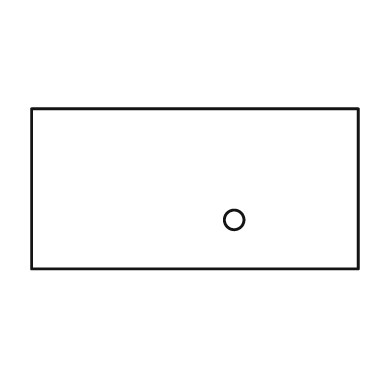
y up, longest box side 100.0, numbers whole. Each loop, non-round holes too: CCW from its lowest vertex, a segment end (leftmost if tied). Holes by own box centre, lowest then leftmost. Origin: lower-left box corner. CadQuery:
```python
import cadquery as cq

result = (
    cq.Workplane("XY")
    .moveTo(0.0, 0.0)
    .lineTo(100.0, 0.0)
    .lineTo(100.0, 49.0)
    .lineTo(0.0, 49.0)
    .close()
    .moveTo(62.0, 15.0)
    .circle(3.0)
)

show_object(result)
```